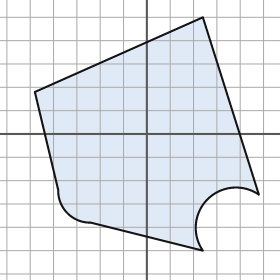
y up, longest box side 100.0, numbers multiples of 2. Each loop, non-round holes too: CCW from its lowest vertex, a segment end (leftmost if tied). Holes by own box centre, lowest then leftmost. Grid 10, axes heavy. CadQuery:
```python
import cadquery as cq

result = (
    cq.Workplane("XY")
    .moveTo(24.0, -50.0)
    .threePointArc((26.0, -28.0), (48.0, -26.0))
    .lineTo(24.0, 50.0)
    .lineTo(-48.0, 18.0)
    .lineTo(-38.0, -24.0)
    .threePointArc((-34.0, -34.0), (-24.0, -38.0))
    .close()
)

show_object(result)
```